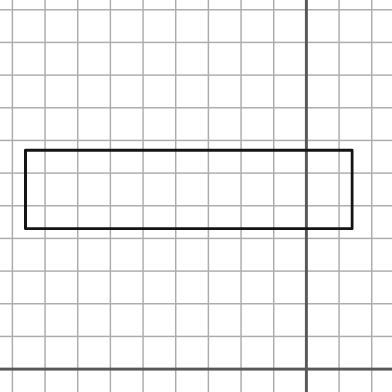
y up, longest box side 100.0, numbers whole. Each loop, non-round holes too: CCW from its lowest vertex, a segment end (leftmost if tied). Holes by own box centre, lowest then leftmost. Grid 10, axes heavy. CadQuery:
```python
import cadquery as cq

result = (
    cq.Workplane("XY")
    .moveTo(-86.0, 43.0)
    .lineTo(14.0, 43.0)
    .lineTo(14.0, 67.0)
    .lineTo(-86.0, 67.0)
    .close()
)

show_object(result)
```